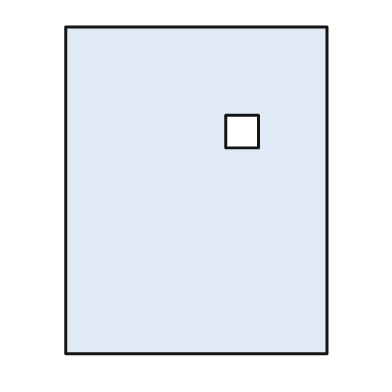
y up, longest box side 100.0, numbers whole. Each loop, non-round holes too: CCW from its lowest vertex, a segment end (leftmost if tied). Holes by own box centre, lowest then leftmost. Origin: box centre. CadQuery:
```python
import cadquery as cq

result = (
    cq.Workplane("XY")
    .moveTo(-40.0, -50.0)
    .lineTo(40.0, -50.0)
    .lineTo(40.0, 50.0)
    .lineTo(-40.0, 50.0)
    .close()
    .moveTo(9.0, 13.0)
    .lineTo(19.0, 13.0)
    .lineTo(19.0, 23.0)
    .lineTo(9.0, 23.0)
    .close()
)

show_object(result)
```